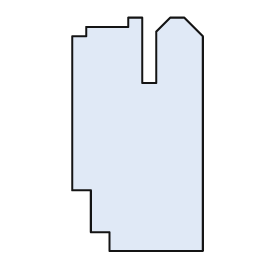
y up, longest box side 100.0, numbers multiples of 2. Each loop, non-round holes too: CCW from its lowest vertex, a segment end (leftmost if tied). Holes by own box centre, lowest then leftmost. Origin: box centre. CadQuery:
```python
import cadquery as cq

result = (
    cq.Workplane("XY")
    .moveTo(-12.0, -50.0)
    .lineTo(28.0, -50.0)
    .lineTo(28.0, 42.0)
    .lineTo(20.0, 50.0)
    .lineTo(14.0, 50.0)
    .lineTo(8.0, 44.0)
    .lineTo(8.0, 22.0)
    .lineTo(2.0, 22.0)
    .lineTo(2.0, 50.0)
    .lineTo(-4.0, 50.0)
    .lineTo(-4.0, 46.0)
    .lineTo(-22.0, 46.0)
    .lineTo(-22.0, 42.0)
    .lineTo(-28.0, 42.0)
    .lineTo(-28.0, -24.0)
    .lineTo(-20.0, -24.0)
    .lineTo(-20.0, -42.0)
    .lineTo(-12.0, -42.0)
    .close()
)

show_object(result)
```